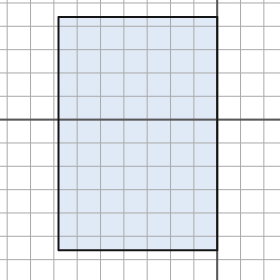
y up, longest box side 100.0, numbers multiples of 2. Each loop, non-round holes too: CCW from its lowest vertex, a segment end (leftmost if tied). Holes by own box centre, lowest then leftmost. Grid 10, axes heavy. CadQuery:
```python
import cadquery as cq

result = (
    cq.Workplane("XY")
    .moveTo(-68.0, -56.0)
    .lineTo(0.0, -56.0)
    .lineTo(0.0, 44.0)
    .lineTo(-68.0, 44.0)
    .close()
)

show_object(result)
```